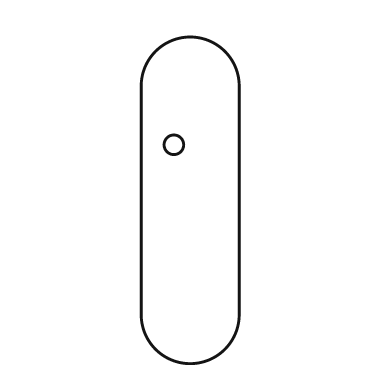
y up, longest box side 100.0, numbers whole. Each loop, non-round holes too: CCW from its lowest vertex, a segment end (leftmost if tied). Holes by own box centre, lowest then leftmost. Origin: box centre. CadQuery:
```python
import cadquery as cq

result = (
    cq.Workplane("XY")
    .moveTo(-15.0, -35.0)
    .threePointArc((0.0, -50.0), (15.0, -35.0))
    .lineTo(15.0, 35.0)
    .threePointArc((0.0, 50.0), (-15.0, 35.0))
    .close()
    .moveTo(-5.0, 17.0)
    .circle(3.0)
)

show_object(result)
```